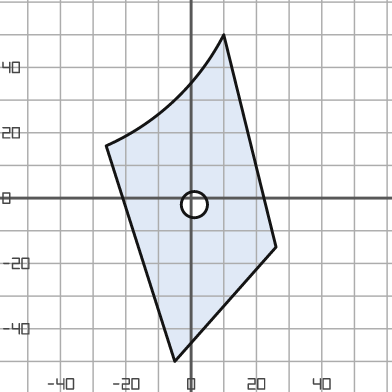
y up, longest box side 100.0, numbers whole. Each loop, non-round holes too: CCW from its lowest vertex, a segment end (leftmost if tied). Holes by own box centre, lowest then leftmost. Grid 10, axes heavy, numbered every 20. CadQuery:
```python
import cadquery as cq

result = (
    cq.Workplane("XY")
    .moveTo(-5.0, -50.0)
    .lineTo(26.0, -15.0)
    .lineTo(10.0, 50.0)
    .threePointArc((-5.0, 30.0), (-26.0, 16.0))
    .close()
    .moveTo(1.0, -2.0)
    .circle(4.0)
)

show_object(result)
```